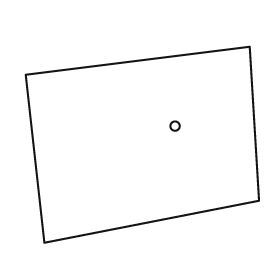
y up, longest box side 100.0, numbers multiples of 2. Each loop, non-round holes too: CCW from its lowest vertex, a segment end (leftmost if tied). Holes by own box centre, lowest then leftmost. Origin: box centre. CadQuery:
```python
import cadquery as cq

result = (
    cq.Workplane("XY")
    .moveTo(-42.0, -42.0)
    .lineTo(50.0, -24.0)
    .lineTo(46.0, 42.0)
    .lineTo(-50.0, 30.0)
    .close()
    .moveTo(14.0, 8.0)
    .circle(2.0)
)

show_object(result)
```